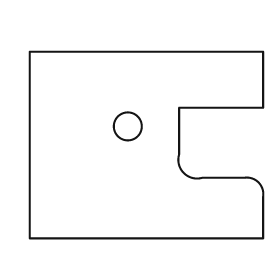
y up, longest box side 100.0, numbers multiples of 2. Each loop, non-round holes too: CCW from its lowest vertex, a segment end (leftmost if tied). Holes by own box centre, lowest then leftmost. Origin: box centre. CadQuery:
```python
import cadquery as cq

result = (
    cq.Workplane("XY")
    .moveTo(-50.0, -40.0)
    .lineTo(50.0, -40.0)
    .lineTo(50.0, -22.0)
    .threePointArc((48.0, -16.0), (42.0, -14.0))
    .lineTo(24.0, -14.0)
    .threePointArc((16.0, -12.0), (14.0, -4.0))
    .lineTo(14.0, 16.0)
    .lineTo(50.0, 16.0)
    .lineTo(50.0, 40.0)
    .lineTo(-50.0, 40.0)
    .close()
    .moveTo(-8.0, 8.0)
    .circle(6.0)
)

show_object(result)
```